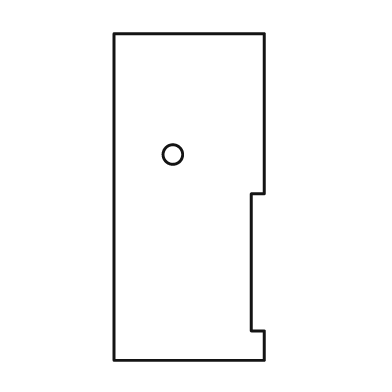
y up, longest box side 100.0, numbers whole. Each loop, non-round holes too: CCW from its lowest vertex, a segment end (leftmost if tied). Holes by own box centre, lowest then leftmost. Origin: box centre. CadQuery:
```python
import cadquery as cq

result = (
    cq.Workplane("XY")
    .moveTo(-23.0, -50.0)
    .lineTo(23.0, -50.0)
    .lineTo(23.0, -41.0)
    .lineTo(19.0, -41.0)
    .lineTo(19.0, 1.0)
    .lineTo(23.0, 1.0)
    .lineTo(23.0, 50.0)
    .lineTo(-23.0, 50.0)
    .close()
    .moveTo(-5.0, 13.0)
    .circle(3.0)
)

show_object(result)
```